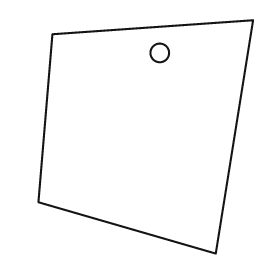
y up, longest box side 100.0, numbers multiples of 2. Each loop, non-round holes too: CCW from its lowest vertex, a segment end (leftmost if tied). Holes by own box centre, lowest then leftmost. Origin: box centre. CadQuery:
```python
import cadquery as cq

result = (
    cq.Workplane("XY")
    .moveTo(30.0, -50.0)
    .lineTo(46.0, 50.0)
    .lineTo(-40.0, 44.0)
    .lineTo(-46.0, -28.0)
    .close()
    .moveTo(6.0, 36.0)
    .circle(4.0)
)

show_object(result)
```